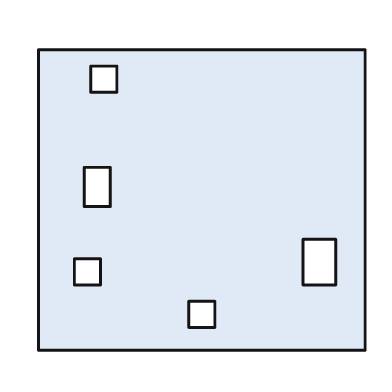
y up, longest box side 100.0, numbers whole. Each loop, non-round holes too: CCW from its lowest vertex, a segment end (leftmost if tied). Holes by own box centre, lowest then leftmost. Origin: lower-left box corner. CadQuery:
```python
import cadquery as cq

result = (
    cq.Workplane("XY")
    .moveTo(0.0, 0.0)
    .lineTo(100.0, 0.0)
    .lineTo(100.0, 92.0)
    .lineTo(0.0, 92.0)
    .close()
    .moveTo(46.0, 7.0)
    .lineTo(54.0, 7.0)
    .lineTo(54.0, 15.0)
    .lineTo(46.0, 15.0)
    .close()
    .moveTo(11.0, 20.0)
    .lineTo(19.0, 20.0)
    .lineTo(19.0, 28.0)
    .lineTo(11.0, 28.0)
    .close()
    .moveTo(81.0, 20.0)
    .lineTo(91.0, 20.0)
    .lineTo(91.0, 34.0)
    .lineTo(81.0, 34.0)
    .close()
    .moveTo(14.0, 44.0)
    .lineTo(22.0, 44.0)
    .lineTo(22.0, 56.0)
    .lineTo(14.0, 56.0)
    .close()
    .moveTo(16.0, 79.0)
    .lineTo(24.0, 79.0)
    .lineTo(24.0, 87.0)
    .lineTo(16.0, 87.0)
    .close()
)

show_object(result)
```